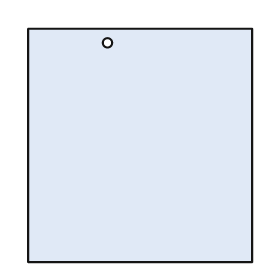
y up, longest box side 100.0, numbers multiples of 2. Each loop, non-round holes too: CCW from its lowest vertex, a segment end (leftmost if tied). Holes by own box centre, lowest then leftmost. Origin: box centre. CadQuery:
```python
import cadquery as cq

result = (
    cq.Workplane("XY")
    .moveTo(-48.0, -50.0)
    .lineTo(48.0, -50.0)
    .lineTo(48.0, 50.0)
    .lineTo(-48.0, 50.0)
    .close()
    .moveTo(-14.0, 44.0)
    .circle(2.0)
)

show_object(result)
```